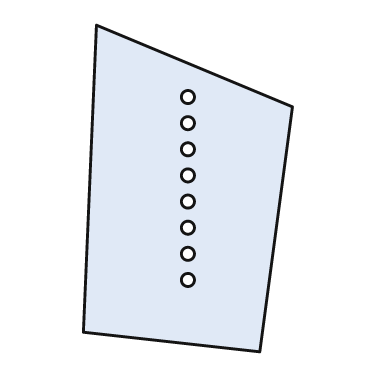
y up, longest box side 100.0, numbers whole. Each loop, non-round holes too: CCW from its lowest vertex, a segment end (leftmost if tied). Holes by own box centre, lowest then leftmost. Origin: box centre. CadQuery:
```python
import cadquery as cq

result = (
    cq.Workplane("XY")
    .moveTo(22.0, -50.0)
    .lineTo(32.0, 25.0)
    .lineTo(-28.0, 50.0)
    .lineTo(-32.0, -44.0)
    .close()
    .moveTo(0.0, -28.0)
    .circle(2.0)
    .moveTo(0.0, -20.0)
    .circle(2.0)
    .moveTo(0.0, -12.0)
    .circle(2.0)
    .moveTo(0.0, -4.0)
    .circle(2.0)
    .moveTo(0.0, 4.0)
    .circle(2.0)
    .moveTo(0.0, 12.0)
    .circle(2.0)
    .moveTo(0.0, 20.0)
    .circle(2.0)
    .moveTo(0.0, 28.0)
    .circle(2.0)
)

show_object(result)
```